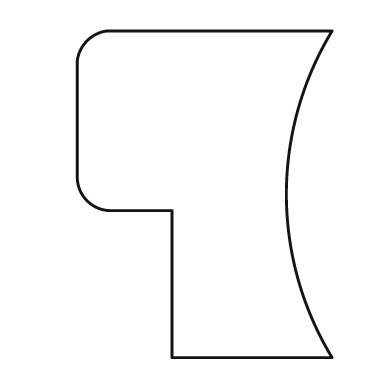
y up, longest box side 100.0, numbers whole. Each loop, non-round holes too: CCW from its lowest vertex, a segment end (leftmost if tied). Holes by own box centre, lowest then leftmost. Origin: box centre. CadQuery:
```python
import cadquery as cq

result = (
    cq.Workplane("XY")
    .moveTo(-10.0, -50.0)
    .lineTo(39.0, -50.0)
    .threePointArc((25.0, 0.0), (39.0, 50.0))
    .lineTo(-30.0, 50.0)
    .threePointArc((-36.0, 47.0), (-39.0, 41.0))
    .lineTo(-39.0, 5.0)
    .threePointArc((-36.0, -2.0), (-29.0, -5.0))
    .lineTo(-10.0, -5.0)
    .close()
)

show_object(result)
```